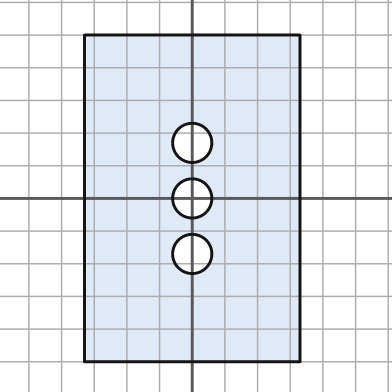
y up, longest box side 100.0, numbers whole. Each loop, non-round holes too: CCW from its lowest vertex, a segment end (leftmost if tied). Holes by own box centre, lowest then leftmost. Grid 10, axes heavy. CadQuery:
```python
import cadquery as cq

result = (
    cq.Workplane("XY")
    .moveTo(-33.0, -50.0)
    .lineTo(33.0, -50.0)
    .lineTo(33.0, 50.0)
    .lineTo(-33.0, 50.0)
    .close()
    .moveTo(0.0, -17.0)
    .circle(6.0)
    .moveTo(0.0, 0.0)
    .circle(6.0)
    .moveTo(0.0, 17.0)
    .circle(6.0)
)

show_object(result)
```